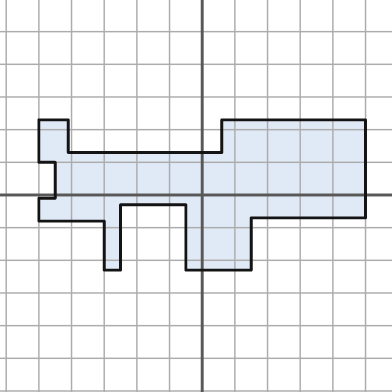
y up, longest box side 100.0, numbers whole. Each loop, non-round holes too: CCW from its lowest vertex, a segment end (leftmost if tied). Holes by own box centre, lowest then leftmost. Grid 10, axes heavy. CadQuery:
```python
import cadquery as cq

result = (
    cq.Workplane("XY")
    .moveTo(-30.0, -23.0)
    .lineTo(-25.0, -23.0)
    .lineTo(-25.0, -3.0)
    .lineTo(-5.0, -3.0)
    .lineTo(-5.0, -23.0)
    .lineTo(15.0, -23.0)
    .lineTo(15.0, -7.0)
    .lineTo(50.0, -7.0)
    .lineTo(50.0, 23.0)
    .lineTo(6.0, 23.0)
    .lineTo(6.0, 13.0)
    .lineTo(-41.0, 13.0)
    .lineTo(-41.0, 23.0)
    .lineTo(-50.0, 23.0)
    .lineTo(-50.0, 10.0)
    .lineTo(-45.0, 10.0)
    .lineTo(-45.0, -1.0)
    .lineTo(-50.0, -1.0)
    .lineTo(-50.0, -8.0)
    .lineTo(-30.0, -8.0)
    .close()
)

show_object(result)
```